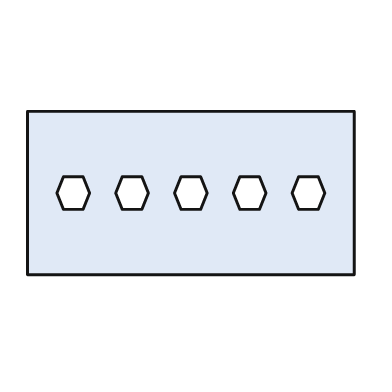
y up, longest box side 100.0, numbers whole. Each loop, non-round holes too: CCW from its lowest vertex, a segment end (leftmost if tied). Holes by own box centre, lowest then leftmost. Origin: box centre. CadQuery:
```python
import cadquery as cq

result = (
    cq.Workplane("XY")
    .moveTo(-50.0, -25.0)
    .lineTo(50.0, -25.0)
    .lineTo(50.0, 25.0)
    .lineTo(-50.0, 25.0)
    .close()
    .moveTo(-39.0, -5.0)
    .lineTo(-33.0, -5.0)
    .lineTo(-31.0, 0.0)
    .lineTo(-33.0, 5.0)
    .lineTo(-39.0, 5.0)
    .lineTo(-41.0, 0.0)
    .close()
    .moveTo(-21.0, -5.0)
    .lineTo(-15.0, -5.0)
    .lineTo(-13.0, 0.0)
    .lineTo(-15.0, 5.0)
    .lineTo(-21.0, 5.0)
    .lineTo(-23.0, 0.0)
    .close()
    .moveTo(-3.0, -5.0)
    .lineTo(3.0, -5.0)
    .lineTo(5.0, 0.0)
    .lineTo(3.0, 5.0)
    .lineTo(-3.0, 5.0)
    .lineTo(-5.0, 0.0)
    .close()
    .moveTo(15.0, -5.0)
    .lineTo(21.0, -5.0)
    .lineTo(23.0, 0.0)
    .lineTo(21.0, 5.0)
    .lineTo(15.0, 5.0)
    .lineTo(13.0, 0.0)
    .close()
    .moveTo(33.0, -5.0)
    .lineTo(39.0, -5.0)
    .lineTo(41.0, 0.0)
    .lineTo(39.0, 5.0)
    .lineTo(33.0, 5.0)
    .lineTo(31.0, 0.0)
    .close()
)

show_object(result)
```